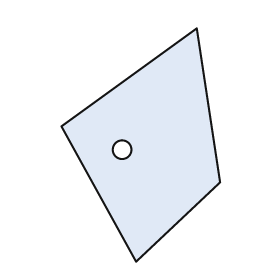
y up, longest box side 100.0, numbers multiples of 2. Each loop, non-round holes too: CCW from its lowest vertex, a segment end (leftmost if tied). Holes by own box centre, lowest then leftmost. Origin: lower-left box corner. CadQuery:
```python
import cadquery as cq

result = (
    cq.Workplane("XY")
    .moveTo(32.0, 0.0)
    .lineTo(68.0, 34.0)
    .lineTo(58.0, 100.0)
    .lineTo(0.0, 58.0)
    .close()
    .moveTo(26.0, 48.0)
    .circle(4.0)
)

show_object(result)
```